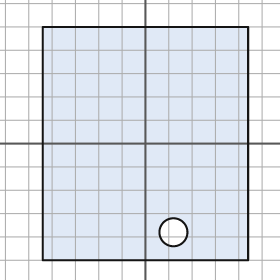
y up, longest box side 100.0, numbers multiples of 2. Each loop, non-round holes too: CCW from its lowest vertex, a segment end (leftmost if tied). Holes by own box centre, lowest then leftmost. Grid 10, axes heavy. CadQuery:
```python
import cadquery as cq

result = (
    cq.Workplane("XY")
    .moveTo(-44.0, -50.0)
    .lineTo(44.0, -50.0)
    .lineTo(44.0, 50.0)
    .lineTo(-44.0, 50.0)
    .close()
    .moveTo(12.0, -38.0)
    .circle(6.0)
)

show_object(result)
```